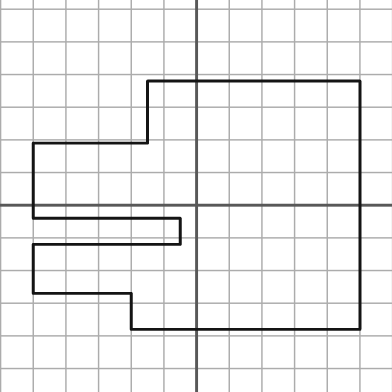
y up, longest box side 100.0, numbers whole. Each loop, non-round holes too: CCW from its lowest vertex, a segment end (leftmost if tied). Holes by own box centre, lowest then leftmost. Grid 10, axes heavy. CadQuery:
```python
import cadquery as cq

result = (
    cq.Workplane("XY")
    .moveTo(-20.0, -38.0)
    .lineTo(50.0, -38.0)
    .lineTo(50.0, 38.0)
    .lineTo(-15.0, 38.0)
    .lineTo(-15.0, 19.0)
    .lineTo(-50.0, 19.0)
    .lineTo(-50.0, -4.0)
    .lineTo(-5.0, -4.0)
    .lineTo(-5.0, -12.0)
    .lineTo(-50.0, -12.0)
    .lineTo(-50.0, -27.0)
    .lineTo(-20.0, -27.0)
    .close()
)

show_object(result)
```